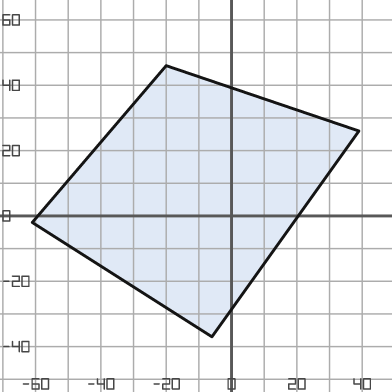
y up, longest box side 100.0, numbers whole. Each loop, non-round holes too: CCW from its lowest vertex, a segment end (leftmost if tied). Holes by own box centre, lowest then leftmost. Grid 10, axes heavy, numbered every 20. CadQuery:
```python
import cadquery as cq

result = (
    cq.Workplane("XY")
    .moveTo(-6.0, -37.0)
    .lineTo(39.0, 26.0)
    .lineTo(-20.0, 46.0)
    .lineTo(-61.0, -2.0)
    .close()
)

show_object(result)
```